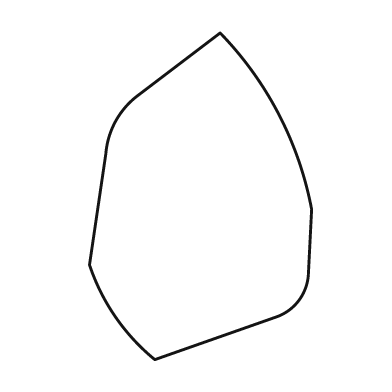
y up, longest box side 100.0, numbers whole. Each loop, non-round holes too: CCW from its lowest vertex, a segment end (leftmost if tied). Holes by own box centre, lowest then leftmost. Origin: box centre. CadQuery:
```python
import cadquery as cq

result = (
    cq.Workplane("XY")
    .moveTo(-14.0, -50.0)
    .lineTo(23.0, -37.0)
    .threePointArc((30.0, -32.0), (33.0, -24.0))
    .lineTo(34.0, -4.0)
    .threePointArc((24.0, 25.0), (6.0, 50.0))
    .lineTo(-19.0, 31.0)
    .threePointArc((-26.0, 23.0), (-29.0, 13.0))
    .lineTo(-34.0, -21.0)
    .threePointArc((-26.0, -37.0), (-14.0, -50.0))
    .close()
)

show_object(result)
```